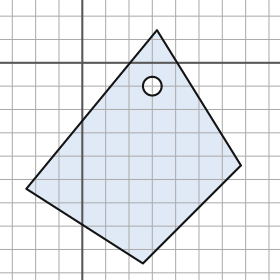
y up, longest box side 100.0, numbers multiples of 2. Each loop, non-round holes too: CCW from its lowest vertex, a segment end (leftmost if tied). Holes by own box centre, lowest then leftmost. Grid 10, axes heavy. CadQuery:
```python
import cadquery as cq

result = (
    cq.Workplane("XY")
    .moveTo(26.0, -86.0)
    .lineTo(68.0, -44.0)
    .lineTo(32.0, 14.0)
    .lineTo(-24.0, -54.0)
    .close()
    .moveTo(30.0, -10.0)
    .circle(4.0)
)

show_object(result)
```